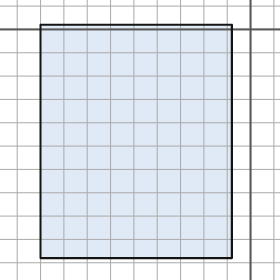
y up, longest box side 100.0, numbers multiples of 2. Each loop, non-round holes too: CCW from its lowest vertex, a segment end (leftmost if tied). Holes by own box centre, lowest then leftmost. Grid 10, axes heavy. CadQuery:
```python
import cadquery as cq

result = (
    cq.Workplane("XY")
    .moveTo(-90.0, -98.0)
    .lineTo(-8.0, -98.0)
    .lineTo(-8.0, 2.0)
    .lineTo(-90.0, 2.0)
    .close()
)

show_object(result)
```